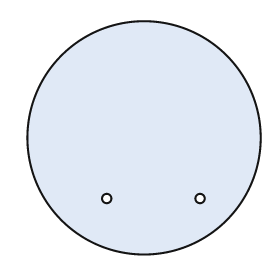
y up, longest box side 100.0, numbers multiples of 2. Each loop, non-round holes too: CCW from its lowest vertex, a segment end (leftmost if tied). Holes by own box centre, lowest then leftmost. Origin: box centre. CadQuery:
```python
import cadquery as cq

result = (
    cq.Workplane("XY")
    .moveTo(0.0, 0.0)
    .circle(50.0)
    .moveTo(-16.0, -26.0)
    .circle(2.0)
    .moveTo(24.0, -26.0)
    .circle(2.0)
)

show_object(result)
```